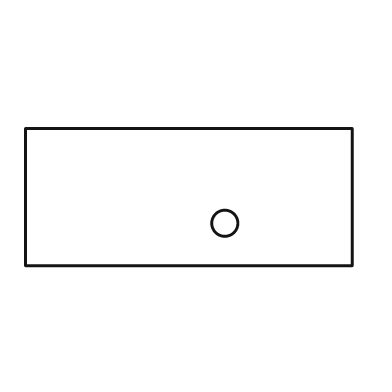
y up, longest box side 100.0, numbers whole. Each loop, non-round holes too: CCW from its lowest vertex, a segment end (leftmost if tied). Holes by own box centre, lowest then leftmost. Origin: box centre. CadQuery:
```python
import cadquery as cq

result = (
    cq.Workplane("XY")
    .moveTo(-50.0, -21.0)
    .lineTo(50.0, -21.0)
    .lineTo(50.0, 21.0)
    .lineTo(-50.0, 21.0)
    .close()
    .moveTo(11.0, -8.0)
    .circle(4.0)
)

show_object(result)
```